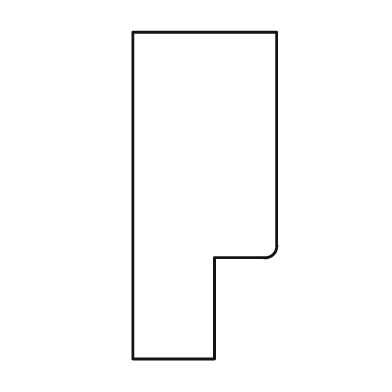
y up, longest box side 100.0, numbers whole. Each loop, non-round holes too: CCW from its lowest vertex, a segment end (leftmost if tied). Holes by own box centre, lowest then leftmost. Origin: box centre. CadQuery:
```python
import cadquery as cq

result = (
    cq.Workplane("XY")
    .moveTo(-22.0, -50.0)
    .lineTo(3.0, -50.0)
    .lineTo(3.0, -19.0)
    .lineTo(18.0, -19.0)
    .threePointArc((21.0, -18.0), (22.0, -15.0))
    .lineTo(22.0, 50.0)
    .lineTo(-22.0, 50.0)
    .close()
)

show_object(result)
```